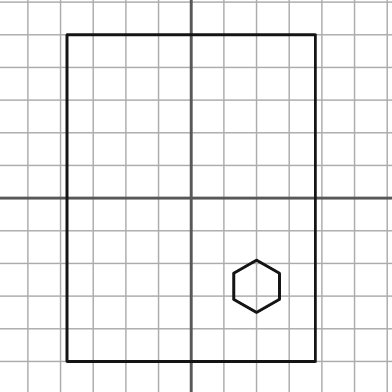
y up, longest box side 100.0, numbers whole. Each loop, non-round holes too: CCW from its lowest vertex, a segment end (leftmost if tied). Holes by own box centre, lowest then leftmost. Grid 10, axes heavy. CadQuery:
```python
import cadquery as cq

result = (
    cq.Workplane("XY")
    .moveTo(-38.0, -50.0)
    .lineTo(38.0, -50.0)
    .lineTo(38.0, 50.0)
    .lineTo(-38.0, 50.0)
    .close()
    .moveTo(20.0, -35.0)
    .lineTo(27.0, -31.0)
    .lineTo(27.0, -23.0)
    .lineTo(20.0, -19.0)
    .lineTo(13.0, -23.0)
    .lineTo(13.0, -31.0)
    .close()
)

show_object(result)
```